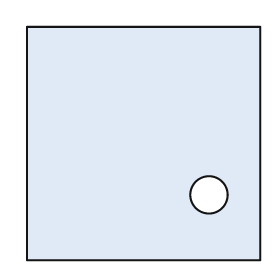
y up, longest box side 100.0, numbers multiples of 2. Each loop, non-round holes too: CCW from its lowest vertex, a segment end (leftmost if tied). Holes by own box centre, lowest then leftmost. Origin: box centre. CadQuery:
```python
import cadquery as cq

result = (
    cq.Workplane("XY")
    .moveTo(-50.0, -50.0)
    .lineTo(50.0, -50.0)
    .lineTo(50.0, 50.0)
    .lineTo(-50.0, 50.0)
    .close()
    .moveTo(28.0, -22.0)
    .circle(8.0)
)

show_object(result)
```